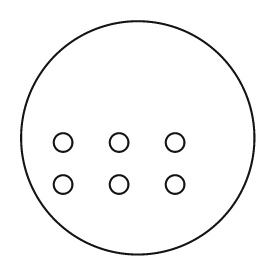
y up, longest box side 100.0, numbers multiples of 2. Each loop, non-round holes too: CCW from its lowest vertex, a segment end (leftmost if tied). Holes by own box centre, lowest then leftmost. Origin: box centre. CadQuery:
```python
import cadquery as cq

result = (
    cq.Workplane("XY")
    .moveTo(0.0, 0.0)
    .circle(50.0)
    .moveTo(-32.0, -20.0)
    .circle(4.0)
    .moveTo(-8.0, -20.0)
    .circle(4.0)
    .moveTo(16.0, -20.0)
    .circle(4.0)
    .moveTo(-32.0, -2.0)
    .circle(4.0)
    .moveTo(-8.0, -2.0)
    .circle(4.0)
    .moveTo(16.0, -2.0)
    .circle(4.0)
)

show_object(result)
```